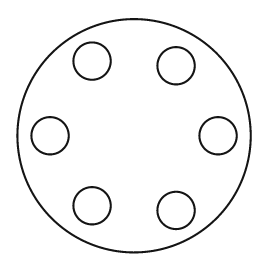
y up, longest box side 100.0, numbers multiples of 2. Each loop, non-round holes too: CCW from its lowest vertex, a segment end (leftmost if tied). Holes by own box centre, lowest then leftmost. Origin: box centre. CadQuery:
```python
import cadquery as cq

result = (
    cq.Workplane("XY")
    .moveTo(0.0, 0.0)
    .circle(50.0)
    .moveTo(18.0, -32.0)
    .circle(8.0)
    .moveTo(-18.0, -30.0)
    .circle(8.0)
    .moveTo(-36.0, 0.0)
    .circle(8.0)
    .moveTo(36.0, 0.0)
    .circle(8.0)
    .moveTo(18.0, 30.0)
    .circle(8.0)
    .moveTo(-18.0, 32.0)
    .circle(8.0)
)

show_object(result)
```